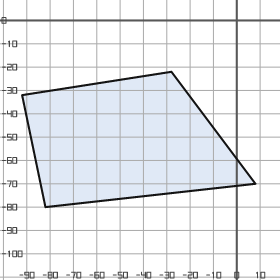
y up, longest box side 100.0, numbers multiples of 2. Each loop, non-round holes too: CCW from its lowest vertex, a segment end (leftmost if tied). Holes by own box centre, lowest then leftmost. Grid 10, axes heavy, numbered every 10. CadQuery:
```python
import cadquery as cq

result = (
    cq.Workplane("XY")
    .moveTo(-82.0, -80.0)
    .lineTo(8.0, -70.0)
    .lineTo(-28.0, -22.0)
    .lineTo(-92.0, -32.0)
    .close()
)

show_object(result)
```